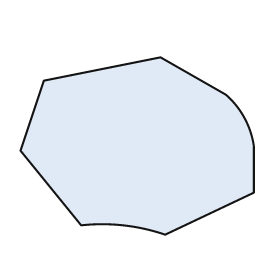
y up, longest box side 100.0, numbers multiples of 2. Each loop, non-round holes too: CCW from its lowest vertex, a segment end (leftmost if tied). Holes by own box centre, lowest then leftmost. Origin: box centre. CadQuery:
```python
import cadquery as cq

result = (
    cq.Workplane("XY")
    .moveTo(12.0, -38.0)
    .lineTo(50.0, -20.0)
    .lineTo(50.0, 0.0)
    .threePointArc((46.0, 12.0), (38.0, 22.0))
    .lineTo(10.0, 38.0)
    .lineTo(-40.0, 28.0)
    .lineTo(-50.0, -2.0)
    .lineTo(-24.0, -34.0)
    .threePointArc((-6.0, -34.0), (12.0, -38.0))
    .close()
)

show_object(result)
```